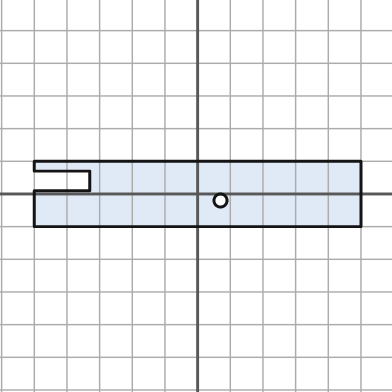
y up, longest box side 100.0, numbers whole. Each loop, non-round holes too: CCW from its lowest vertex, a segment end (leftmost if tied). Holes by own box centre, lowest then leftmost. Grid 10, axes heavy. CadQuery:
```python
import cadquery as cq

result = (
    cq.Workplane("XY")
    .moveTo(-50.0, -10.0)
    .lineTo(50.0, -10.0)
    .lineTo(50.0, 10.0)
    .lineTo(-50.0, 10.0)
    .lineTo(-50.0, 7.0)
    .lineTo(-33.0, 7.0)
    .lineTo(-33.0, 1.0)
    .lineTo(-50.0, 1.0)
    .close()
    .moveTo(7.0, -2.0)
    .circle(2.0)
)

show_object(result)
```